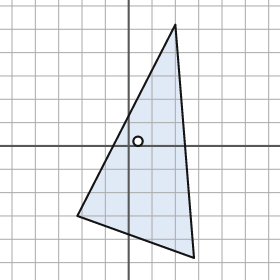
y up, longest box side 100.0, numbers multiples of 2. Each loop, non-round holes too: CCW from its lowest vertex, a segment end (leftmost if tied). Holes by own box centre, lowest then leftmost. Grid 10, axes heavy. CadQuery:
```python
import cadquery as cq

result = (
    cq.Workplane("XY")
    .moveTo(28.0, -48.0)
    .lineTo(20.0, 52.0)
    .lineTo(-22.0, -30.0)
    .close()
    .moveTo(4.0, 2.0)
    .circle(2.0)
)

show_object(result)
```